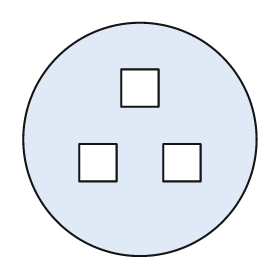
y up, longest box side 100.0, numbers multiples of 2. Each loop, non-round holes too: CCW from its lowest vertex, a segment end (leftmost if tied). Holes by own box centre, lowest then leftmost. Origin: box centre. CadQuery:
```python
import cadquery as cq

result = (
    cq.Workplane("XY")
    .moveTo(0.0, 0.0)
    .circle(50.0)
    .moveTo(-26.0, -18.0)
    .lineTo(-10.0, -18.0)
    .lineTo(-10.0, -2.0)
    .lineTo(-26.0, -2.0)
    .close()
    .moveTo(10.0, -18.0)
    .lineTo(26.0, -18.0)
    .lineTo(26.0, -2.0)
    .lineTo(10.0, -2.0)
    .close()
    .moveTo(-8.0, 14.0)
    .lineTo(8.0, 14.0)
    .lineTo(8.0, 30.0)
    .lineTo(-8.0, 30.0)
    .close()
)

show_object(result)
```